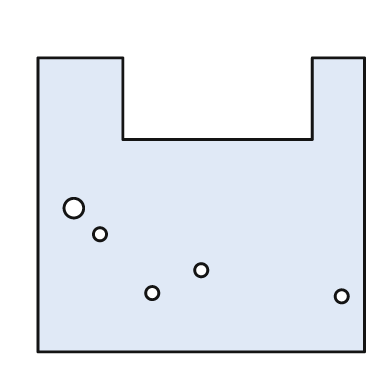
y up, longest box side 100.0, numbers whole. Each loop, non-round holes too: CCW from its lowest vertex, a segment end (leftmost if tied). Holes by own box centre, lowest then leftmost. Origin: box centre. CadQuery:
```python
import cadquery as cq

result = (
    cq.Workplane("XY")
    .moveTo(-50.0, -45.0)
    .lineTo(50.0, -45.0)
    .lineTo(50.0, 45.0)
    .lineTo(34.0, 45.0)
    .lineTo(34.0, 20.0)
    .lineTo(-24.0, 20.0)
    .lineTo(-24.0, 45.0)
    .lineTo(-50.0, 45.0)
    .close()
    .moveTo(43.0, -28.0)
    .circle(2.0)
    .moveTo(-15.0, -27.0)
    .circle(2.0)
    .moveTo(0.0, -20.0)
    .circle(2.0)
    .moveTo(-31.0, -9.0)
    .circle(2.0)
    .moveTo(-39.0, -1.0)
    .circle(3.0)
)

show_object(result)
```